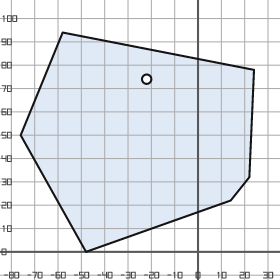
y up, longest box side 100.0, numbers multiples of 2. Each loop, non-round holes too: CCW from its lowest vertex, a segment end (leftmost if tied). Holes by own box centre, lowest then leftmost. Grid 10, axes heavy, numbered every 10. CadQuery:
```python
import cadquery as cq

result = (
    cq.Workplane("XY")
    .moveTo(-48.0, 0.0)
    .lineTo(14.0, 22.0)
    .lineTo(22.0, 32.0)
    .lineTo(24.0, 78.0)
    .lineTo(-58.0, 94.0)
    .lineTo(-76.0, 50.0)
    .close()
    .moveTo(-22.0, 74.0)
    .circle(2.0)
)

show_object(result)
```